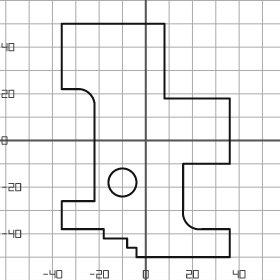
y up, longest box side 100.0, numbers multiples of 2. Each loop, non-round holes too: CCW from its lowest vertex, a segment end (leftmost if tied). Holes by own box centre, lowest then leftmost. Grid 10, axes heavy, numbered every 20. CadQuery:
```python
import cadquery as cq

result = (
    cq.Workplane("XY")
    .moveTo(-4.0, -50.0)
    .lineTo(36.0, -50.0)
    .lineTo(36.0, -38.0)
    .lineTo(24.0, -38.0)
    .threePointArc((18.0, -36.0), (16.0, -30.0))
    .lineTo(16.0, -10.0)
    .lineTo(36.0, -10.0)
    .lineTo(36.0, 18.0)
    .lineTo(8.0, 18.0)
    .lineTo(8.0, 50.0)
    .lineTo(-36.0, 50.0)
    .lineTo(-36.0, 22.0)
    .lineTo(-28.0, 22.0)
    .threePointArc((-24.0, 20.0), (-22.0, 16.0))
    .lineTo(-22.0, -26.0)
    .lineTo(-36.0, -26.0)
    .lineTo(-36.0, -38.0)
    .lineTo(-18.0, -38.0)
    .lineTo(-18.0, -42.0)
    .lineTo(-8.0, -42.0)
    .lineTo(-8.0, -46.0)
    .lineTo(-4.0, -46.0)
    .close()
    .moveTo(-10.0, -18.0)
    .circle(6.0)
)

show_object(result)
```